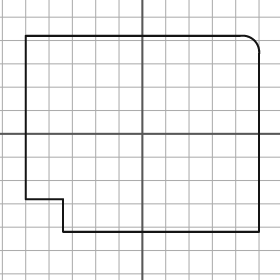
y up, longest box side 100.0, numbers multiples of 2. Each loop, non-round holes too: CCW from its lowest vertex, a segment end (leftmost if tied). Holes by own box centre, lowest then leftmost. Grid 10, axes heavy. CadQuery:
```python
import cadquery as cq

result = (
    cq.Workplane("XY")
    .moveTo(-34.0, -42.0)
    .lineTo(50.0, -42.0)
    .lineTo(50.0, 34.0)
    .threePointArc((48.0, 40.0), (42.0, 42.0))
    .lineTo(-50.0, 42.0)
    .lineTo(-50.0, -28.0)
    .lineTo(-34.0, -28.0)
    .close()
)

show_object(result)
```